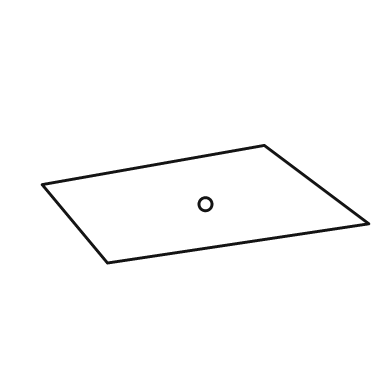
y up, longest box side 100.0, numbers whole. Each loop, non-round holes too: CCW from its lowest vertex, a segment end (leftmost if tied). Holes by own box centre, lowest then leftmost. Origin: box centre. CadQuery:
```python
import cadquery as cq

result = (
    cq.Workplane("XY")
    .moveTo(-30.0, -18.0)
    .lineTo(50.0, -6.0)
    .lineTo(18.0, 18.0)
    .lineTo(-50.0, 6.0)
    .close()
    .moveTo(0.0, 0.0)
    .circle(2.0)
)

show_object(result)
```